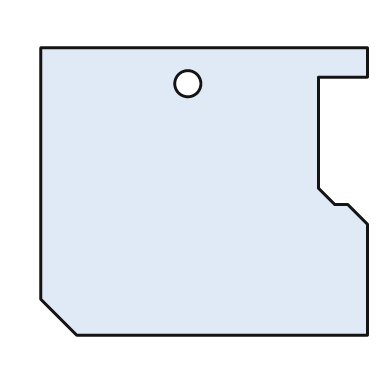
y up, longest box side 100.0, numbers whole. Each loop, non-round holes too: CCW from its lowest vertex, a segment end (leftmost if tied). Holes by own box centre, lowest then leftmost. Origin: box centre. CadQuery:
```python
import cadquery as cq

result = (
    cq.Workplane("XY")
    .moveTo(-39.0, -44.0)
    .lineTo(50.0, -44.0)
    .lineTo(50.0, -10.0)
    .lineTo(44.0, -4.0)
    .lineTo(40.0, -4.0)
    .lineTo(35.0, 1.0)
    .lineTo(35.0, 35.0)
    .lineTo(50.0, 35.0)
    .lineTo(50.0, 44.0)
    .lineTo(-50.0, 44.0)
    .lineTo(-50.0, -33.0)
    .close()
    .moveTo(-5.0, 33.0)
    .circle(4.0)
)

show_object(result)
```